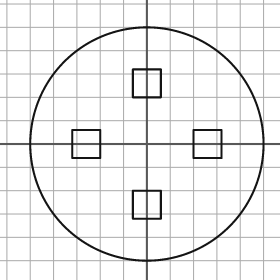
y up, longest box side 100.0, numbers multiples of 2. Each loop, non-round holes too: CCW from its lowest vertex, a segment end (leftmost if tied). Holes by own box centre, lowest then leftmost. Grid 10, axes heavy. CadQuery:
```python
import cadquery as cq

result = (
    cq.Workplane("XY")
    .moveTo(0.0, 0.0)
    .circle(50.0)
    .moveTo(-6.0, -32.0)
    .lineTo(6.0, -32.0)
    .lineTo(6.0, -20.0)
    .lineTo(-6.0, -20.0)
    .close()
    .moveTo(-32.0, -6.0)
    .lineTo(-20.0, -6.0)
    .lineTo(-20.0, 6.0)
    .lineTo(-32.0, 6.0)
    .close()
    .moveTo(20.0, -6.0)
    .lineTo(32.0, -6.0)
    .lineTo(32.0, 6.0)
    .lineTo(20.0, 6.0)
    .close()
    .moveTo(-6.0, 20.0)
    .lineTo(6.0, 20.0)
    .lineTo(6.0, 32.0)
    .lineTo(-6.0, 32.0)
    .close()
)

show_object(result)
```